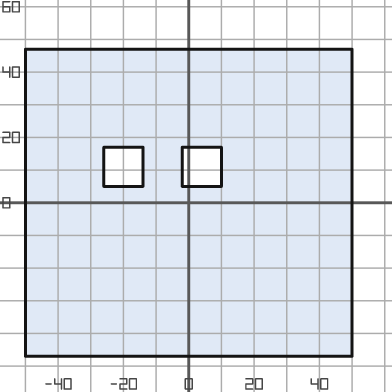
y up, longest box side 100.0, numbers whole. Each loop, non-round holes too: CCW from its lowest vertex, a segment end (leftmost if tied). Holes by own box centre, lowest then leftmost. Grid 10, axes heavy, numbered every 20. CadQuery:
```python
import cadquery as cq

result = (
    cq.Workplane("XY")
    .moveTo(-50.0, -47.0)
    .lineTo(50.0, -47.0)
    .lineTo(50.0, 47.0)
    .lineTo(-50.0, 47.0)
    .close()
    .moveTo(-26.0, 5.0)
    .lineTo(-14.0, 5.0)
    .lineTo(-14.0, 17.0)
    .lineTo(-26.0, 17.0)
    .close()
    .moveTo(-2.0, 5.0)
    .lineTo(10.0, 5.0)
    .lineTo(10.0, 17.0)
    .lineTo(-2.0, 17.0)
    .close()
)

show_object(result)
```